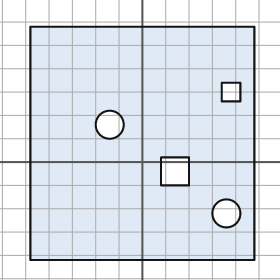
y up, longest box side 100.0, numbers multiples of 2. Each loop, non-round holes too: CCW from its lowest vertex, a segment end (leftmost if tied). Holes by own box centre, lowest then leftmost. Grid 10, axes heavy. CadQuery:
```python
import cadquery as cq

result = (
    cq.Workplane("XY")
    .moveTo(-48.0, -42.0)
    .lineTo(48.0, -42.0)
    .lineTo(48.0, 58.0)
    .lineTo(-48.0, 58.0)
    .close()
    .moveTo(36.0, -22.0)
    .circle(6.0)
    .moveTo(8.0, -10.0)
    .lineTo(20.0, -10.0)
    .lineTo(20.0, 2.0)
    .lineTo(8.0, 2.0)
    .close()
    .moveTo(-14.0, 16.0)
    .circle(6.0)
    .moveTo(34.0, 26.0)
    .lineTo(42.0, 26.0)
    .lineTo(42.0, 34.0)
    .lineTo(34.0, 34.0)
    .close()
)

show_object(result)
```